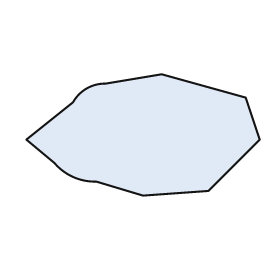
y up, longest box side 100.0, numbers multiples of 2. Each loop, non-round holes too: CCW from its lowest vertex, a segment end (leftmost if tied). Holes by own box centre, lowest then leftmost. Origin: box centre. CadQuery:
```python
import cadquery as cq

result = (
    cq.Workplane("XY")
    .moveTo(0.0, -26.0)
    .lineTo(28.0, -24.0)
    .lineTo(50.0, -2.0)
    .lineTo(44.0, 16.0)
    .lineTo(8.0, 26.0)
    .lineTo(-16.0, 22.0)
    .threePointArc((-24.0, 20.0), (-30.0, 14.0))
    .lineTo(-50.0, -2.0)
    .lineTo(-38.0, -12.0)
    .threePointArc((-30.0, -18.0), (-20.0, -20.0))
    .close()
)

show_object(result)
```